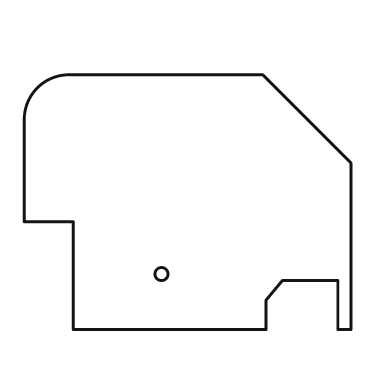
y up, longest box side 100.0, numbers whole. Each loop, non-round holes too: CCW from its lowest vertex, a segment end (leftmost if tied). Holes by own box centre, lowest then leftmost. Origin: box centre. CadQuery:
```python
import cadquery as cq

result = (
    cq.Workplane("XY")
    .moveTo(-35.0, -39.0)
    .lineTo(24.0, -39.0)
    .lineTo(24.0, -30.0)
    .lineTo(29.0, -24.0)
    .lineTo(46.0, -24.0)
    .lineTo(46.0, -39.0)
    .lineTo(50.0, -39.0)
    .lineTo(50.0, 12.0)
    .lineTo(23.0, 39.0)
    .lineTo(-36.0, 39.0)
    .threePointArc((-46.0, 35.0), (-50.0, 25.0))
    .lineTo(-50.0, -6.0)
    .lineTo(-35.0, -6.0)
    .close()
    .moveTo(-8.0, -22.0)
    .circle(2.0)
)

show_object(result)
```